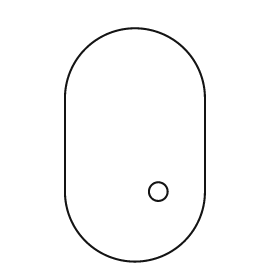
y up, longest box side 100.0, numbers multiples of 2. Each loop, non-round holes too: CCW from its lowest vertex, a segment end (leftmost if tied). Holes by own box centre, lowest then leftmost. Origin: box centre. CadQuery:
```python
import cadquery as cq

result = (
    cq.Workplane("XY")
    .moveTo(-30.0, -20.0)
    .threePointArc((0.0, -50.0), (30.0, -20.0))
    .lineTo(30.0, 20.0)
    .threePointArc((0.0, 50.0), (-30.0, 20.0))
    .close()
    .moveTo(10.0, -20.0)
    .circle(4.0)
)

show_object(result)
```